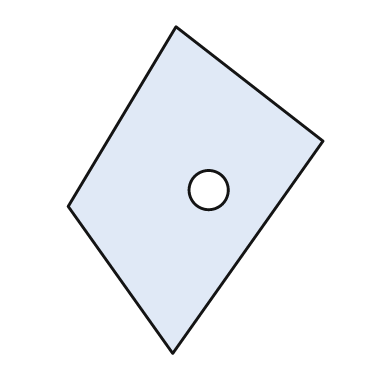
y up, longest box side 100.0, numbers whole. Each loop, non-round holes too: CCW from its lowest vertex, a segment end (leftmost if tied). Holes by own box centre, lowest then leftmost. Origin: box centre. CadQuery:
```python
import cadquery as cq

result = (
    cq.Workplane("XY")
    .moveTo(-7.0, -50.0)
    .lineTo(39.0, 15.0)
    .lineTo(-6.0, 50.0)
    .lineTo(-39.0, -5.0)
    .close()
    .moveTo(4.0, 0.0)
    .circle(6.0)
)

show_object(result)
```